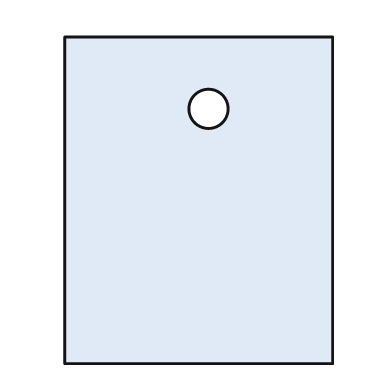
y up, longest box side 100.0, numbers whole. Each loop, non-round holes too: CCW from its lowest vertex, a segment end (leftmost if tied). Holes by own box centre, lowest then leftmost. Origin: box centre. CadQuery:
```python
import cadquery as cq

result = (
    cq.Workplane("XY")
    .moveTo(-41.0, -50.0)
    .lineTo(41.0, -50.0)
    .lineTo(41.0, 50.0)
    .lineTo(-41.0, 50.0)
    .close()
    .moveTo(3.0, 28.0)
    .circle(6.0)
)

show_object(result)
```